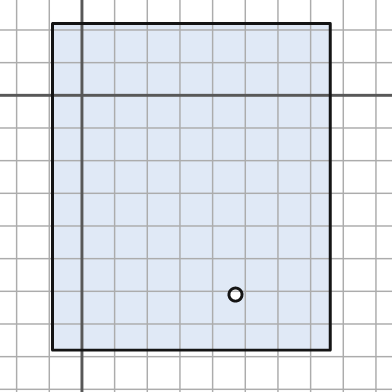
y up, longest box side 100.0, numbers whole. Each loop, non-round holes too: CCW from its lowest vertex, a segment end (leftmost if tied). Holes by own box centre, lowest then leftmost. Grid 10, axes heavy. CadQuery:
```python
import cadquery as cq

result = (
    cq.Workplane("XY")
    .moveTo(-9.0, -78.0)
    .lineTo(76.0, -78.0)
    .lineTo(76.0, 22.0)
    .lineTo(-9.0, 22.0)
    .close()
    .moveTo(47.0, -61.0)
    .circle(2.0)
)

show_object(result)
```